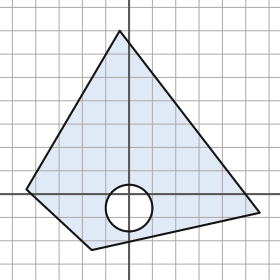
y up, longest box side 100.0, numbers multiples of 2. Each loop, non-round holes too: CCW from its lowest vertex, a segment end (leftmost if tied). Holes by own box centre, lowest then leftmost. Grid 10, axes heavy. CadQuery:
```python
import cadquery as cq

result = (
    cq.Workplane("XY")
    .moveTo(-16.0, -24.0)
    .lineTo(56.0, -8.0)
    .lineTo(-4.0, 70.0)
    .lineTo(-44.0, 2.0)
    .close()
    .moveTo(0.0, -6.0)
    .circle(10.0)
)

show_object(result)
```